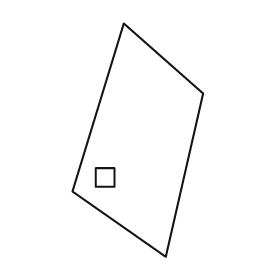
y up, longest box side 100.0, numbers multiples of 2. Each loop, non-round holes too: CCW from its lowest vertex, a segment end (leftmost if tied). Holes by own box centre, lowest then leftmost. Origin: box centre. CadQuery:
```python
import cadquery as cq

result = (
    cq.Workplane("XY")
    .moveTo(12.0, -50.0)
    .lineTo(28.0, 20.0)
    .lineTo(-6.0, 50.0)
    .lineTo(-28.0, -22.0)
    .close()
    .moveTo(-18.0, -20.0)
    .lineTo(-10.0, -20.0)
    .lineTo(-10.0, -12.0)
    .lineTo(-18.0, -12.0)
    .close()
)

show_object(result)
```